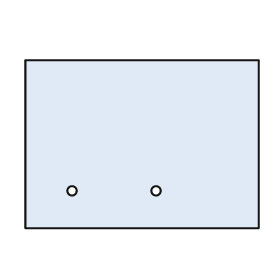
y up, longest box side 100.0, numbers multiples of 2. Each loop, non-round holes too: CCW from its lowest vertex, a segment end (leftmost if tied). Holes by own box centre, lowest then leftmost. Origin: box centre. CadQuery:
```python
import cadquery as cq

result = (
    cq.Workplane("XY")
    .moveTo(-50.0, -36.0)
    .lineTo(50.0, -36.0)
    .lineTo(50.0, 36.0)
    .lineTo(-50.0, 36.0)
    .close()
    .moveTo(-30.0, -20.0)
    .circle(2.0)
    .moveTo(6.0, -20.0)
    .circle(2.0)
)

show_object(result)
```